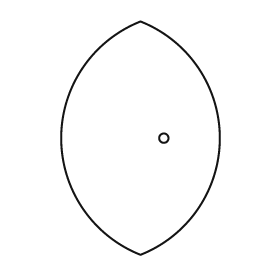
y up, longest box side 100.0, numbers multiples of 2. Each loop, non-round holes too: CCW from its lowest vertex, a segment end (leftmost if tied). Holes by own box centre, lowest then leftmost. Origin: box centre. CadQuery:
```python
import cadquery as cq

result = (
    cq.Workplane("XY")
    .moveTo(0.0, -50.0)
    .threePointArc((34.0, 0.0), (0.0, 50.0))
    .threePointArc((-34.0, 0.0), (0.0, -50.0))
    .close()
    .moveTo(10.0, 0.0)
    .circle(2.0)
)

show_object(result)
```